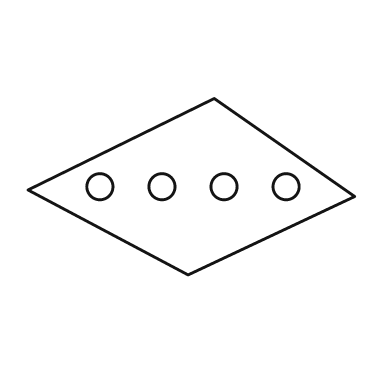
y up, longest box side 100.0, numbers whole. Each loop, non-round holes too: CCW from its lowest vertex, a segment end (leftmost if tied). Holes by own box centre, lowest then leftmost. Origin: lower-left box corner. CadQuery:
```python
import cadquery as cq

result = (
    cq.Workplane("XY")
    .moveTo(49.0, 0.0)
    .lineTo(100.0, 24.0)
    .lineTo(57.0, 54.0)
    .lineTo(0.0, 26.0)
    .close()
    .moveTo(22.0, 27.0)
    .circle(4.0)
    .moveTo(41.0, 27.0)
    .circle(4.0)
    .moveTo(60.0, 27.0)
    .circle(4.0)
    .moveTo(79.0, 27.0)
    .circle(4.0)
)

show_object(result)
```